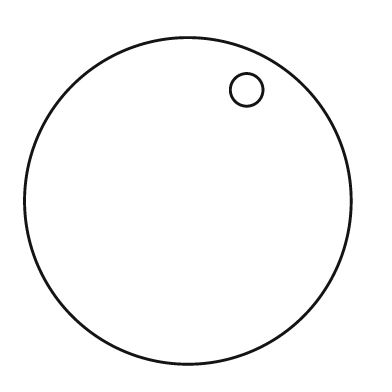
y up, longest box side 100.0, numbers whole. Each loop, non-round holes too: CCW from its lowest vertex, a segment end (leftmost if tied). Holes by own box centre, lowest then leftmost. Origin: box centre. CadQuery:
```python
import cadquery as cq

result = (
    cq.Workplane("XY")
    .moveTo(0.0, 0.0)
    .circle(50.0)
    .moveTo(18.0, 34.0)
    .circle(5.0)
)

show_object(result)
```